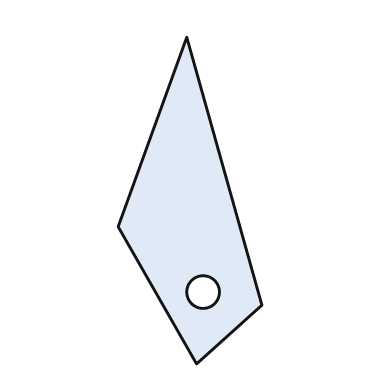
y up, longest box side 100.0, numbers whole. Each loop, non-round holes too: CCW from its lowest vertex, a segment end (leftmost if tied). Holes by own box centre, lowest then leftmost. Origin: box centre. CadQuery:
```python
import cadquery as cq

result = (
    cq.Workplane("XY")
    .moveTo(2.0, -50.0)
    .lineTo(22.0, -32.0)
    .lineTo(-1.0, 50.0)
    .lineTo(-22.0, -8.0)
    .close()
    .moveTo(4.0, -28.0)
    .circle(5.0)
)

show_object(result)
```